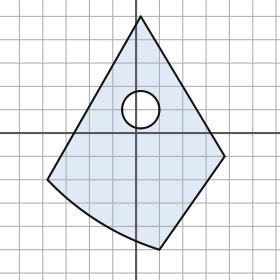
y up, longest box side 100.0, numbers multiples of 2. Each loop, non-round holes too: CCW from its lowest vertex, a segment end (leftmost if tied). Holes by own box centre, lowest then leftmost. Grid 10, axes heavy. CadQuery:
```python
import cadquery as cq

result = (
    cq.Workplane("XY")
    .moveTo(10.0, -50.0)
    .lineTo(38.0, -10.0)
    .lineTo(2.0, 50.0)
    .lineTo(-38.0, -20.0)
    .threePointArc((-16.0, -38.0), (10.0, -50.0))
    .close()
    .moveTo(2.0, 10.0)
    .circle(8.0)
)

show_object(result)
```